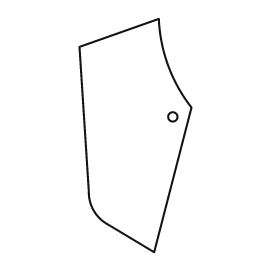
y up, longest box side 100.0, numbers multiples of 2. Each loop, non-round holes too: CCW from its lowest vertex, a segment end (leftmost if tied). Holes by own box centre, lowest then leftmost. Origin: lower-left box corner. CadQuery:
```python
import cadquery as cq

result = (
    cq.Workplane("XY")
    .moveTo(32.0, 0.0)
    .lineTo(48.0, 62.0)
    .threePointArc((38.0, 80.0), (34.0, 100.0))
    .lineTo(0.0, 88.0)
    .lineTo(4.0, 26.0)
    .threePointArc((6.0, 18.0), (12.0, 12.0))
    .close()
    .moveTo(40.0, 58.0)
    .circle(2.0)
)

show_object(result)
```